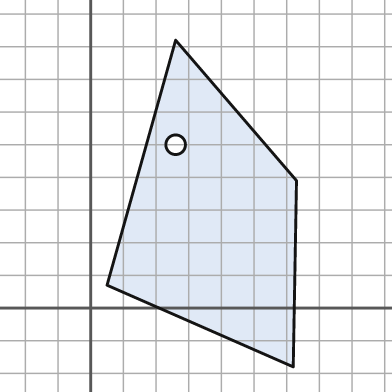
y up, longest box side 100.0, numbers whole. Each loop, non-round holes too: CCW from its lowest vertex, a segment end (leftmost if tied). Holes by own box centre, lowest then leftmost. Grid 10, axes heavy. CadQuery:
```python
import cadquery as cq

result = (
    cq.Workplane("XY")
    .moveTo(62.0, -18.0)
    .lineTo(63.0, 39.0)
    .lineTo(26.0, 82.0)
    .lineTo(5.0, 7.0)
    .close()
    .moveTo(26.0, 50.0)
    .circle(3.0)
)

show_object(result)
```